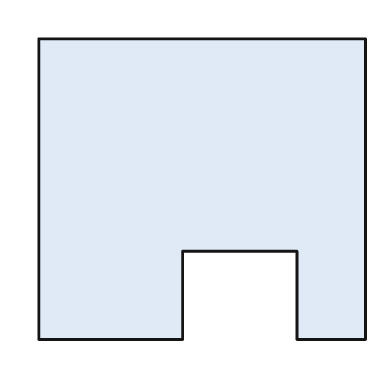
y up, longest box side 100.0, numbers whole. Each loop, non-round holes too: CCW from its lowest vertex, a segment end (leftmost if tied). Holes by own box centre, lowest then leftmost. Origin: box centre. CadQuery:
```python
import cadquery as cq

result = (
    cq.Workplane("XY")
    .moveTo(-50.0, -46.0)
    .lineTo(-6.0, -46.0)
    .lineTo(-6.0, -19.0)
    .lineTo(29.0, -19.0)
    .lineTo(29.0, -46.0)
    .lineTo(50.0, -46.0)
    .lineTo(50.0, 46.0)
    .lineTo(-50.0, 46.0)
    .close()
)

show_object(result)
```